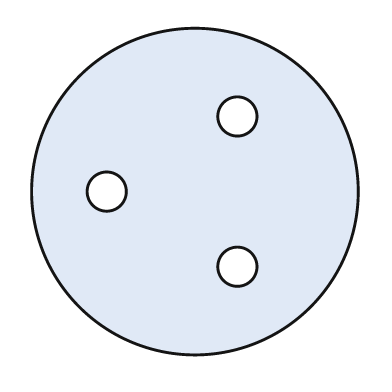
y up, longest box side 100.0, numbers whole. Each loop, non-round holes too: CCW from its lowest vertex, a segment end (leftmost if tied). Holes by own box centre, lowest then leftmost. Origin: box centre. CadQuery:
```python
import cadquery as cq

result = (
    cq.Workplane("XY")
    .moveTo(0.0, 0.0)
    .circle(50.0)
    .moveTo(13.0, -23.0)
    .circle(6.0)
    .moveTo(-27.0, 0.0)
    .circle(6.0)
    .moveTo(13.0, 23.0)
    .circle(6.0)
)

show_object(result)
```